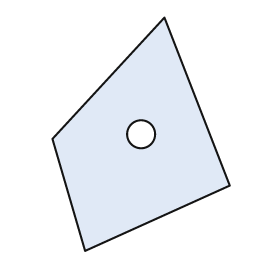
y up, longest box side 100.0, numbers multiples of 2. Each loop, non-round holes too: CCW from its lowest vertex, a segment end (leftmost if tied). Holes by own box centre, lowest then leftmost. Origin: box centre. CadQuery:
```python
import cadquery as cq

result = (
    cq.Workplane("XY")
    .moveTo(-24.0, -50.0)
    .lineTo(38.0, -22.0)
    .lineTo(10.0, 50.0)
    .lineTo(-38.0, -2.0)
    .close()
    .moveTo(0.0, 0.0)
    .circle(6.0)
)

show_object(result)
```